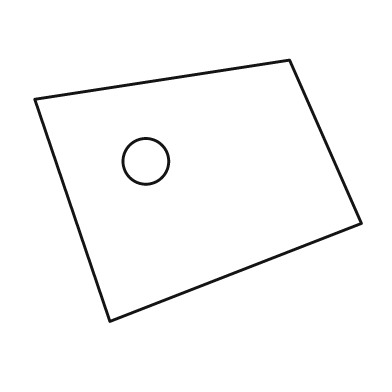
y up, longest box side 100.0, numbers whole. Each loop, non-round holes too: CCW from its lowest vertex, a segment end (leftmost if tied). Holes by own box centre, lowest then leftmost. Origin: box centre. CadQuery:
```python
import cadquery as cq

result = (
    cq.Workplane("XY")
    .moveTo(-27.0, -40.0)
    .lineTo(50.0, -10.0)
    .lineTo(28.0, 40.0)
    .lineTo(-50.0, 28.0)
    .close()
    .moveTo(-16.0, 9.0)
    .circle(7.0)
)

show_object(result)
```